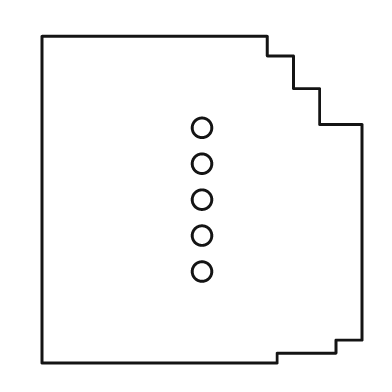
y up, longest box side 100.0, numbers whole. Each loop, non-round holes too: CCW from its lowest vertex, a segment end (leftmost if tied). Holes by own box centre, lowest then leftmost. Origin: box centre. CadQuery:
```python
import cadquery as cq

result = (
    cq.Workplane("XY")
    .moveTo(-49.0, -50.0)
    .lineTo(23.0, -50.0)
    .lineTo(23.0, -47.0)
    .lineTo(41.0, -47.0)
    .lineTo(41.0, -43.0)
    .lineTo(49.0, -43.0)
    .lineTo(49.0, 23.0)
    .lineTo(36.0, 23.0)
    .lineTo(36.0, 34.0)
    .lineTo(28.0, 34.0)
    .lineTo(28.0, 44.0)
    .lineTo(20.0, 44.0)
    .lineTo(20.0, 50.0)
    .lineTo(-49.0, 50.0)
    .close()
    .moveTo(0.0, -22.0)
    .circle(3.0)
    .moveTo(0.0, -11.0)
    .circle(3.0)
    .moveTo(0.0, 0.0)
    .circle(3.0)
    .moveTo(0.0, 11.0)
    .circle(3.0)
    .moveTo(0.0, 22.0)
    .circle(3.0)
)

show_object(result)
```